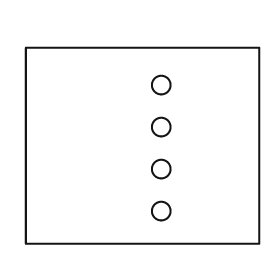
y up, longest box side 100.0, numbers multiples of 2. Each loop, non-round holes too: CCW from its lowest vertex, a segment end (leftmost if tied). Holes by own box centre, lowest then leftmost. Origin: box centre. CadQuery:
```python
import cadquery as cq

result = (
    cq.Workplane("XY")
    .moveTo(-50.0, -42.0)
    .lineTo(50.0, -42.0)
    .lineTo(50.0, 42.0)
    .lineTo(-50.0, 42.0)
    .close()
    .moveTo(8.0, -28.0)
    .circle(4.0)
    .moveTo(8.0, -10.0)
    .circle(4.0)
    .moveTo(8.0, 8.0)
    .circle(4.0)
    .moveTo(8.0, 26.0)
    .circle(4.0)
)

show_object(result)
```